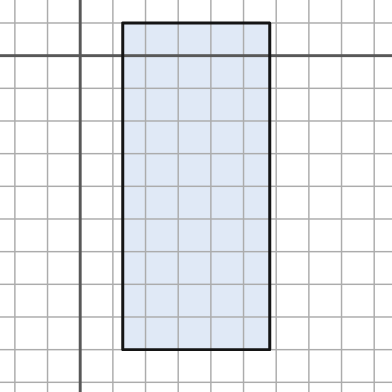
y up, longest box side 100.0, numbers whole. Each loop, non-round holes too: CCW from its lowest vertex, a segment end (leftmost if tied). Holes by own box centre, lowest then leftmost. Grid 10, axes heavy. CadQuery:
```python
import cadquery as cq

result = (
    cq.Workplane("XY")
    .moveTo(13.0, -90.0)
    .lineTo(58.0, -90.0)
    .lineTo(58.0, 10.0)
    .lineTo(13.0, 10.0)
    .close()
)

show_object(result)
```